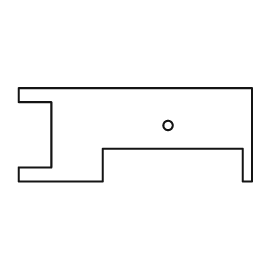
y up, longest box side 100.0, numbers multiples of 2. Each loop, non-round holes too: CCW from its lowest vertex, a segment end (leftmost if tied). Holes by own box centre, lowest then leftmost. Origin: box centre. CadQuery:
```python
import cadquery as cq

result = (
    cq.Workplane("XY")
    .moveTo(-50.0, -20.0)
    .lineTo(-14.0, -20.0)
    .lineTo(-14.0, -6.0)
    .lineTo(46.0, -6.0)
    .lineTo(46.0, -20.0)
    .lineTo(50.0, -20.0)
    .lineTo(50.0, 20.0)
    .lineTo(-50.0, 20.0)
    .lineTo(-50.0, 14.0)
    .lineTo(-36.0, 14.0)
    .lineTo(-36.0, -14.0)
    .lineTo(-50.0, -14.0)
    .close()
    .moveTo(14.0, 4.0)
    .circle(2.0)
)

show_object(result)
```